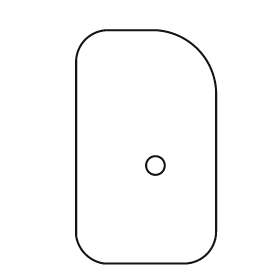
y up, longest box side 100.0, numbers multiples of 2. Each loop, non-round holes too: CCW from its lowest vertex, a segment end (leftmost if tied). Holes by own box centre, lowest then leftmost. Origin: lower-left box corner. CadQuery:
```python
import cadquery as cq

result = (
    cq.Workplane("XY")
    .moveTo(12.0, 0.0)
    .lineTo(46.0, 0.0)
    .threePointArc((56.0, 4.0), (60.0, 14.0))
    .lineTo(60.0, 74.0)
    .threePointArc((52.0, 92.0), (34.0, 100.0))
    .lineTo(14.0, 100.0)
    .threePointArc((4.0, 96.0), (0.0, 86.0))
    .lineTo(0.0, 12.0)
    .threePointArc((4.0, 4.0), (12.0, 0.0))
    .close()
    .moveTo(34.0, 42.0)
    .circle(4.0)
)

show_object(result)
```